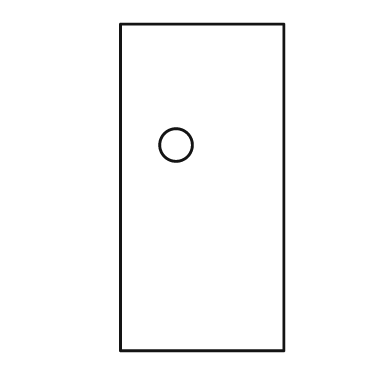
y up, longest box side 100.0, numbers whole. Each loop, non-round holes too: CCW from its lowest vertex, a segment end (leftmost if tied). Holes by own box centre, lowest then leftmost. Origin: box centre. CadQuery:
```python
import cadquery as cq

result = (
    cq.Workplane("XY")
    .moveTo(-25.0, -50.0)
    .lineTo(25.0, -50.0)
    .lineTo(25.0, 50.0)
    .lineTo(-25.0, 50.0)
    .close()
    .moveTo(-8.0, 13.0)
    .circle(5.0)
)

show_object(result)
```